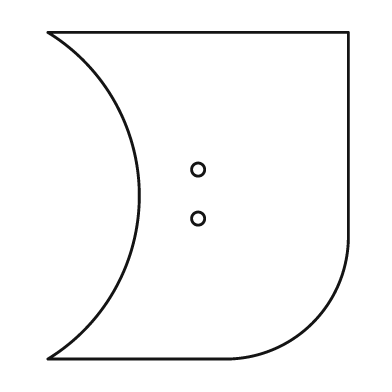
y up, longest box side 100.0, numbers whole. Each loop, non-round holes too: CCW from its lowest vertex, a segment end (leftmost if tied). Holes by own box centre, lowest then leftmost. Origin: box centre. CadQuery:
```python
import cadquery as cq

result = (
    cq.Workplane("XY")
    .moveTo(-46.0, -50.0)
    .lineTo(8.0, -50.0)
    .threePointArc((35.0, -39.0), (46.0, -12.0))
    .lineTo(46.0, 50.0)
    .lineTo(-46.0, 50.0)
    .threePointArc((-18.0, 0.0), (-46.0, -50.0))
    .close()
    .moveTo(0.0, -7.0)
    .circle(2.0)
    .moveTo(0.0, 8.0)
    .circle(2.0)
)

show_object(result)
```